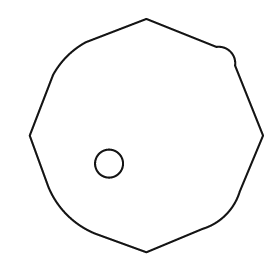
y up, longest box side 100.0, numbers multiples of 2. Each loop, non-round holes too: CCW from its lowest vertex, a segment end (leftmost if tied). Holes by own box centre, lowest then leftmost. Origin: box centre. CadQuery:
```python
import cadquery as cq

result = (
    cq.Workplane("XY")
    .moveTo(0.0, -50.0)
    .lineTo(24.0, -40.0)
    .threePointArc((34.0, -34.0), (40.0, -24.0))
    .lineTo(50.0, 0.0)
    .lineTo(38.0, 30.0)
    .threePointArc((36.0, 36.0), (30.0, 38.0))
    .lineTo(0.0, 50.0)
    .lineTo(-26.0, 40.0)
    .threePointArc((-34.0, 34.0), (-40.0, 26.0))
    .lineTo(-50.0, 0.0)
    .lineTo(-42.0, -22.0)
    .threePointArc((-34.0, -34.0), (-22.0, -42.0))
    .close()
    .moveTo(-16.0, -12.0)
    .circle(6.0)
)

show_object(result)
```